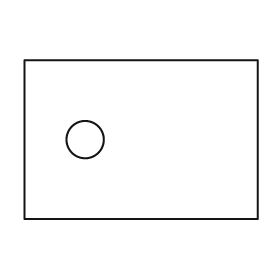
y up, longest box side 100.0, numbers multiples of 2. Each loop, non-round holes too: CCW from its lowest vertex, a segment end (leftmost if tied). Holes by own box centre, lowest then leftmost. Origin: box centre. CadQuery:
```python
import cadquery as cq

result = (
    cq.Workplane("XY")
    .moveTo(-50.0, -34.0)
    .lineTo(50.0, -34.0)
    .lineTo(50.0, 34.0)
    .lineTo(-50.0, 34.0)
    .close()
    .moveTo(-24.0, 0.0)
    .circle(8.0)
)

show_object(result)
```